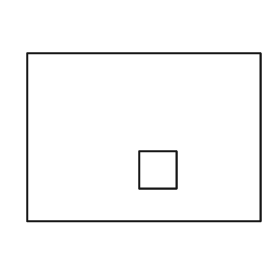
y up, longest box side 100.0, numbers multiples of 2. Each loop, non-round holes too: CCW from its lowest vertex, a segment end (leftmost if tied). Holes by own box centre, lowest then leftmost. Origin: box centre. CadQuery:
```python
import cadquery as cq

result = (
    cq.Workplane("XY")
    .moveTo(-50.0, -36.0)
    .lineTo(50.0, -36.0)
    .lineTo(50.0, 36.0)
    .lineTo(-50.0, 36.0)
    .close()
    .moveTo(-2.0, -22.0)
    .lineTo(14.0, -22.0)
    .lineTo(14.0, -6.0)
    .lineTo(-2.0, -6.0)
    .close()
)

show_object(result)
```